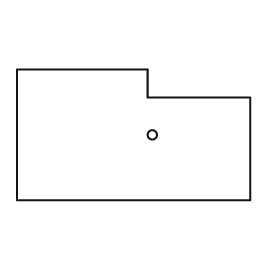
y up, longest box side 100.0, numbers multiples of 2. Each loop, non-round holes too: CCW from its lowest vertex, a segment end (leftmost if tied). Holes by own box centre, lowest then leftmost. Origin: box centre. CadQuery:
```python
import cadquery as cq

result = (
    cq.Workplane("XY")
    .moveTo(-50.0, -28.0)
    .lineTo(50.0, -28.0)
    .lineTo(50.0, 16.0)
    .lineTo(6.0, 16.0)
    .lineTo(6.0, 28.0)
    .lineTo(-50.0, 28.0)
    .close()
    .moveTo(8.0, 0.0)
    .circle(2.0)
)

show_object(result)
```